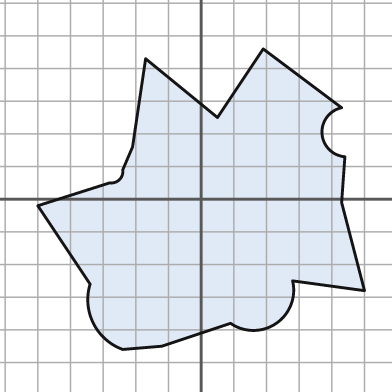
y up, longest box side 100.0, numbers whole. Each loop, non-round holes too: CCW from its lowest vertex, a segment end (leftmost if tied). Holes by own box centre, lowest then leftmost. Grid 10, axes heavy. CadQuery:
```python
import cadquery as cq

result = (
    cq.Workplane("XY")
    .moveTo(-24.0, -46.0)
    .lineTo(-12.0, -45.0)
    .lineTo(9.0, -38.0)
    .threePointArc((23.0, -38.0), (28.0, -25.0))
    .lineTo(50.0, -28.0)
    .lineTo(43.0, -1.0)
    .lineTo(44.0, 13.0)
    .threePointArc((37.0, 20.0), (43.0, 28.0))
    .lineTo(19.0, 46.0)
    .lineTo(5.0, 25.0)
    .lineTo(-17.0, 43.0)
    .lineTo(-21.0, 16.0)
    .lineTo(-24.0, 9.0)
    .threePointArc((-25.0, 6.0), (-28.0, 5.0))
    .lineTo(-50.0, -2.0)
    .lineTo(-34.0, -26.0)
    .threePointArc((-33.0, -38.0), (-24.0, -46.0))
    .close()
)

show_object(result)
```